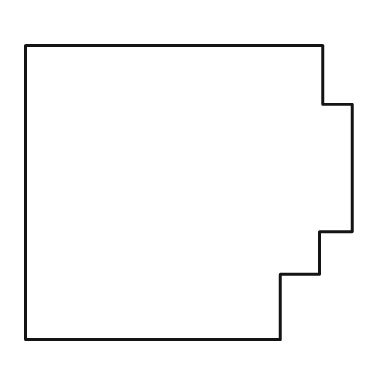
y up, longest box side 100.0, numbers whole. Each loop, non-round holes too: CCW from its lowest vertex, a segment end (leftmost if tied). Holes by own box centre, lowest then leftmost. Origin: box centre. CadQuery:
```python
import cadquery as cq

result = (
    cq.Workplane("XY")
    .moveTo(-50.0, -45.0)
    .lineTo(28.0, -45.0)
    .lineTo(28.0, -25.0)
    .lineTo(40.0, -25.0)
    .lineTo(40.0, -12.0)
    .lineTo(50.0, -12.0)
    .lineTo(50.0, 27.0)
    .lineTo(41.0, 27.0)
    .lineTo(41.0, 45.0)
    .lineTo(-50.0, 45.0)
    .close()
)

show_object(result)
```